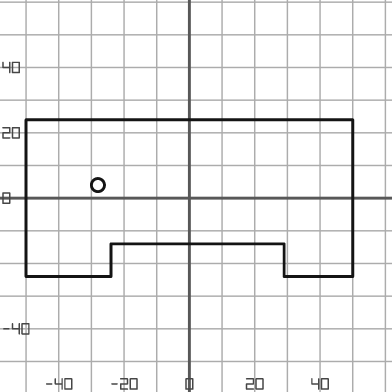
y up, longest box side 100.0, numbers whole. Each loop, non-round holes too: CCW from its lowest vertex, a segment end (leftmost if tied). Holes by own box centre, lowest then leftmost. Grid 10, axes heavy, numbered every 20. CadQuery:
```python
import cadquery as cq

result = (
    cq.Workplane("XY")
    .moveTo(-50.0, -24.0)
    .lineTo(-24.0, -24.0)
    .lineTo(-24.0, -14.0)
    .lineTo(29.0, -14.0)
    .lineTo(29.0, -24.0)
    .lineTo(50.0, -24.0)
    .lineTo(50.0, 24.0)
    .lineTo(-50.0, 24.0)
    .close()
    .moveTo(-28.0, 4.0)
    .circle(2.0)
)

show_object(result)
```